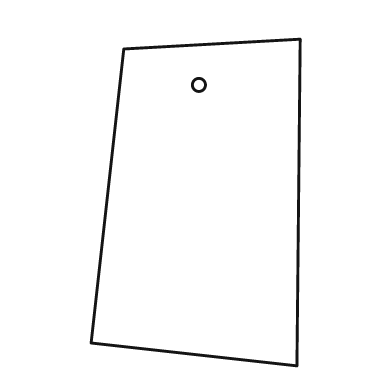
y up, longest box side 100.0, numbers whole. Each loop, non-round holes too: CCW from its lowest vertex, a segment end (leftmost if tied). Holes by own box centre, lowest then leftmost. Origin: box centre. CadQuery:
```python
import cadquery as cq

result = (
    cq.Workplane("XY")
    .moveTo(31.0, -50.0)
    .lineTo(32.0, 50.0)
    .lineTo(-22.0, 47.0)
    .lineTo(-32.0, -43.0)
    .close()
    .moveTo(1.0, 36.0)
    .circle(2.0)
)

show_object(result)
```